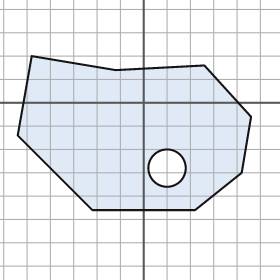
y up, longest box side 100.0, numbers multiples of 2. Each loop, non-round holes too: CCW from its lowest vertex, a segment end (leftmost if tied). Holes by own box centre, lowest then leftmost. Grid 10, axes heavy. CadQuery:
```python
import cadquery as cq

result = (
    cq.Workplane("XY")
    .moveTo(-22.0, -46.0)
    .lineTo(22.0, -46.0)
    .lineTo(42.0, -30.0)
    .lineTo(46.0, -6.0)
    .lineTo(26.0, 16.0)
    .lineTo(-12.0, 14.0)
    .lineTo(-48.0, 20.0)
    .lineTo(-54.0, -14.0)
    .close()
    .moveTo(10.0, -28.0)
    .circle(8.0)
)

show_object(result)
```